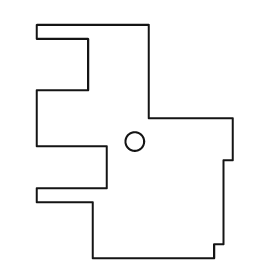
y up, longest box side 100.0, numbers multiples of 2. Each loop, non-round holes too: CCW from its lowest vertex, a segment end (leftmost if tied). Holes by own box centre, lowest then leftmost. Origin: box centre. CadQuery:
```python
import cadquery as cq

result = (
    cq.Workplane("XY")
    .moveTo(-18.0, -50.0)
    .lineTo(34.0, -50.0)
    .lineTo(34.0, -44.0)
    .lineTo(38.0, -44.0)
    .lineTo(38.0, -8.0)
    .lineTo(42.0, -8.0)
    .lineTo(42.0, 10.0)
    .lineTo(6.0, 10.0)
    .lineTo(6.0, 50.0)
    .lineTo(-42.0, 50.0)
    .lineTo(-42.0, 44.0)
    .lineTo(-20.0, 44.0)
    .lineTo(-20.0, 22.0)
    .lineTo(-42.0, 22.0)
    .lineTo(-42.0, -2.0)
    .lineTo(-12.0, -2.0)
    .lineTo(-12.0, -20.0)
    .lineTo(-42.0, -20.0)
    .lineTo(-42.0, -26.0)
    .lineTo(-18.0, -26.0)
    .close()
    .moveTo(0.0, 0.0)
    .circle(4.0)
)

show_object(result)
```